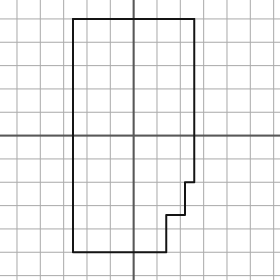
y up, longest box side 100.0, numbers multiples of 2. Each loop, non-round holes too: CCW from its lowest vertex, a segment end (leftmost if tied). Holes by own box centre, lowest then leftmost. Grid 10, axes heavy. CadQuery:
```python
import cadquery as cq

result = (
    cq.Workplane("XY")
    .moveTo(-26.0, -50.0)
    .lineTo(14.0, -50.0)
    .lineTo(14.0, -34.0)
    .lineTo(22.0, -34.0)
    .lineTo(22.0, -20.0)
    .lineTo(26.0, -20.0)
    .lineTo(26.0, 50.0)
    .lineTo(-26.0, 50.0)
    .close()
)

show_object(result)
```